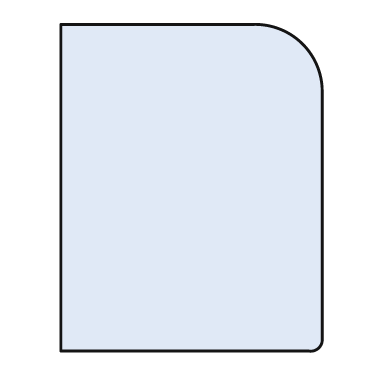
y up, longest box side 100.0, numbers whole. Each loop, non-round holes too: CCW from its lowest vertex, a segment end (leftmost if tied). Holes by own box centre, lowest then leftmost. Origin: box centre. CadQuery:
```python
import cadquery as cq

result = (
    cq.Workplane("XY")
    .moveTo(-40.0, -50.0)
    .lineTo(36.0, -50.0)
    .threePointArc((39.0, -49.0), (40.0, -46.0))
    .lineTo(40.0, 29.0)
    .threePointArc((34.0, 44.0), (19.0, 50.0))
    .lineTo(-40.0, 50.0)
    .close()
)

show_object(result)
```